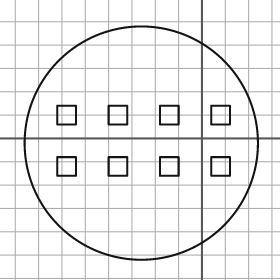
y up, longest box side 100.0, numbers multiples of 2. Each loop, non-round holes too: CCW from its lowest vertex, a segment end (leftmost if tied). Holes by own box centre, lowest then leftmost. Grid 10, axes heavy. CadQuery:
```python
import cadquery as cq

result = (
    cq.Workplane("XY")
    .moveTo(-26.0, -2.0)
    .circle(50.0)
    .moveTo(-62.0, -16.0)
    .lineTo(-54.0, -16.0)
    .lineTo(-54.0, -8.0)
    .lineTo(-62.0, -8.0)
    .close()
    .moveTo(-40.0, -16.0)
    .lineTo(-32.0, -16.0)
    .lineTo(-32.0, -8.0)
    .lineTo(-40.0, -8.0)
    .close()
    .moveTo(-18.0, -16.0)
    .lineTo(-10.0, -16.0)
    .lineTo(-10.0, -8.0)
    .lineTo(-18.0, -8.0)
    .close()
    .moveTo(4.0, -16.0)
    .lineTo(12.0, -16.0)
    .lineTo(12.0, -8.0)
    .lineTo(4.0, -8.0)
    .close()
    .moveTo(-62.0, 6.0)
    .lineTo(-54.0, 6.0)
    .lineTo(-54.0, 14.0)
    .lineTo(-62.0, 14.0)
    .close()
    .moveTo(-40.0, 6.0)
    .lineTo(-32.0, 6.0)
    .lineTo(-32.0, 14.0)
    .lineTo(-40.0, 14.0)
    .close()
    .moveTo(-18.0, 6.0)
    .lineTo(-10.0, 6.0)
    .lineTo(-10.0, 14.0)
    .lineTo(-18.0, 14.0)
    .close()
    .moveTo(4.0, 6.0)
    .lineTo(12.0, 6.0)
    .lineTo(12.0, 14.0)
    .lineTo(4.0, 14.0)
    .close()
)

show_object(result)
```